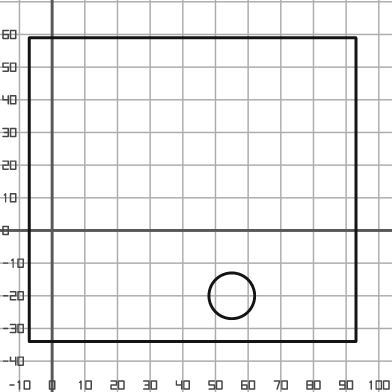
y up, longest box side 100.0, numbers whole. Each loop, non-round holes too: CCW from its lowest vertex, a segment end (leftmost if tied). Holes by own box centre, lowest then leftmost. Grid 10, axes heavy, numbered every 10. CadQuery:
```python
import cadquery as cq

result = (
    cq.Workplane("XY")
    .moveTo(-7.0, -34.0)
    .lineTo(93.0, -34.0)
    .lineTo(93.0, 59.0)
    .lineTo(-7.0, 59.0)
    .close()
    .moveTo(55.0, -20.0)
    .circle(7.0)
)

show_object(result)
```